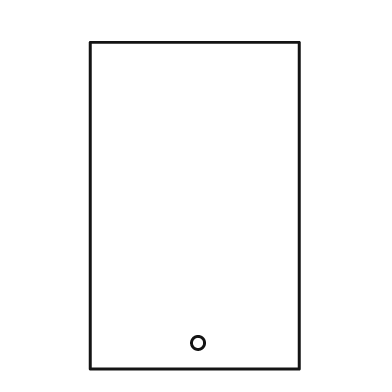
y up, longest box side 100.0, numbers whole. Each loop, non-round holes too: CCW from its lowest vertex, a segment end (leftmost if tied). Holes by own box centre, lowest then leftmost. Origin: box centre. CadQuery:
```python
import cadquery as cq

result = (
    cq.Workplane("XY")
    .moveTo(-32.0, -50.0)
    .lineTo(32.0, -50.0)
    .lineTo(32.0, 50.0)
    .lineTo(-32.0, 50.0)
    .close()
    .moveTo(1.0, -42.0)
    .circle(2.0)
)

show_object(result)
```